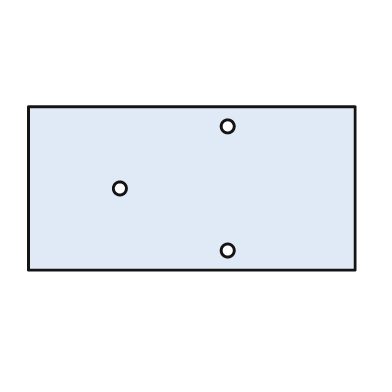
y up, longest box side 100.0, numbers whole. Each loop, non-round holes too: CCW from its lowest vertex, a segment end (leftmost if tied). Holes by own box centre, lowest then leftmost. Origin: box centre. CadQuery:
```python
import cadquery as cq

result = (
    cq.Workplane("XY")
    .moveTo(-50.0, -25.0)
    .lineTo(50.0, -25.0)
    .lineTo(50.0, 25.0)
    .lineTo(-50.0, 25.0)
    .close()
    .moveTo(11.0, -19.0)
    .circle(2.0)
    .moveTo(-22.0, 0.0)
    .circle(2.0)
    .moveTo(11.0, 19.0)
    .circle(2.0)
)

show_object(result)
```